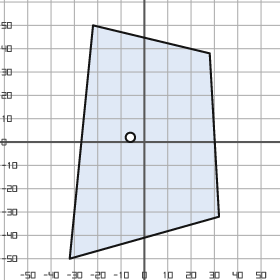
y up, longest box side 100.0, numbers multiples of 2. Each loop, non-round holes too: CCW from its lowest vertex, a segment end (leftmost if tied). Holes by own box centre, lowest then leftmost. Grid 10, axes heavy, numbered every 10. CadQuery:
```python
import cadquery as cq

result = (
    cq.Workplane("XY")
    .moveTo(-32.0, -50.0)
    .lineTo(32.0, -32.0)
    .lineTo(28.0, 38.0)
    .lineTo(-22.0, 50.0)
    .close()
    .moveTo(-6.0, 2.0)
    .circle(2.0)
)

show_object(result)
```